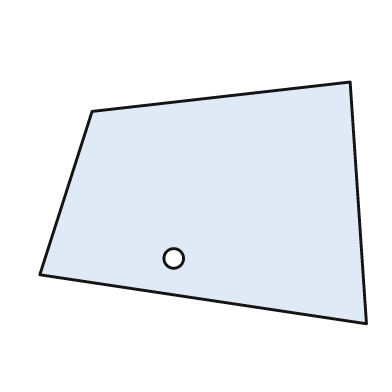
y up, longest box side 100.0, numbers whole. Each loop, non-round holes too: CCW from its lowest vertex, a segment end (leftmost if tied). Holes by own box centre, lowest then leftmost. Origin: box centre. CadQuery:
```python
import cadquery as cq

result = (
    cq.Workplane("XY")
    .moveTo(50.0, -37.0)
    .lineTo(45.0, 37.0)
    .lineTo(-34.0, 28.0)
    .lineTo(-50.0, -22.0)
    .close()
    .moveTo(-9.0, -17.0)
    .circle(3.0)
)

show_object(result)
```